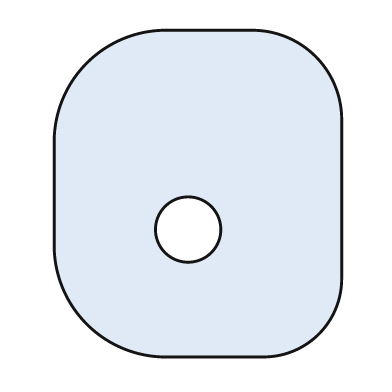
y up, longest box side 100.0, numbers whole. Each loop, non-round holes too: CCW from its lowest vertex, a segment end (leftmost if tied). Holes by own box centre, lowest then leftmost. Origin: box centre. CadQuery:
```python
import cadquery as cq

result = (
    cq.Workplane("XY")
    .moveTo(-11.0, -50.0)
    .lineTo(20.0, -50.0)
    .threePointArc((37.0, -43.0), (44.0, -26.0))
    .lineTo(44.0, 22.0)
    .threePointArc((36.0, 42.0), (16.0, 50.0))
    .lineTo(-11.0, 50.0)
    .threePointArc((-34.0, 40.0), (-44.0, 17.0))
    .lineTo(-44.0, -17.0)
    .threePointArc((-34.0, -40.0), (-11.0, -50.0))
    .close()
    .moveTo(-3.0, -11.0)
    .circle(10.0)
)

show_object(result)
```